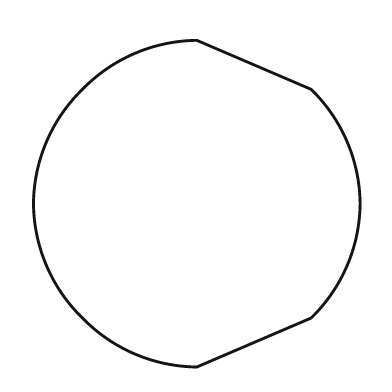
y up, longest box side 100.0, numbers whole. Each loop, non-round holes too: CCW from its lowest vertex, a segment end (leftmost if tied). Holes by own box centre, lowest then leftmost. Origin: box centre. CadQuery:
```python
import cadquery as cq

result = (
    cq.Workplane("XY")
    .moveTo(0.0, -50.0)
    .lineTo(35.0, -35.0)
    .threePointArc((46.0, -19.0), (50.0, 0.0))
    .threePointArc((46.0, 19.0), (35.0, 35.0))
    .lineTo(0.0, 50.0)
    .threePointArc((-19.0, 46.0), (-35.0, 35.0))
    .threePointArc((-46.0, 19.0), (-50.0, 0.0))
    .threePointArc((-46.0, -19.0), (-35.0, -35.0))
    .threePointArc((-19.0, -46.0), (0.0, -50.0))
    .close()
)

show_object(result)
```